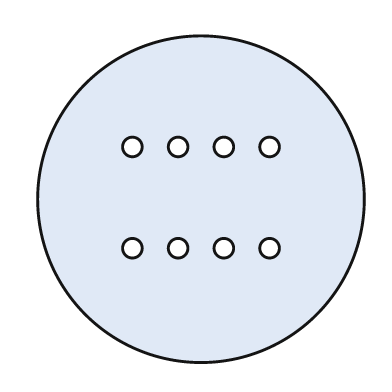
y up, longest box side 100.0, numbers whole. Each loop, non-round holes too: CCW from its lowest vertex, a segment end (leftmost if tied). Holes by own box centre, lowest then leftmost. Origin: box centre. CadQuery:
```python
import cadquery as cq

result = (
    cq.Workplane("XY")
    .moveTo(0.0, 0.0)
    .circle(50.0)
    .moveTo(-21.0, -15.0)
    .circle(3.0)
    .moveTo(-7.0, -15.0)
    .circle(3.0)
    .moveTo(7.0, -15.0)
    .circle(3.0)
    .moveTo(21.0, -15.0)
    .circle(3.0)
    .moveTo(-21.0, 16.0)
    .circle(3.0)
    .moveTo(-7.0, 16.0)
    .circle(3.0)
    .moveTo(7.0, 16.0)
    .circle(3.0)
    .moveTo(21.0, 16.0)
    .circle(3.0)
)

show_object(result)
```